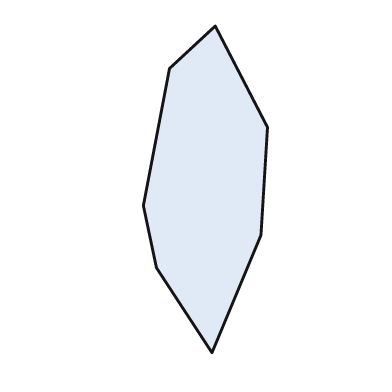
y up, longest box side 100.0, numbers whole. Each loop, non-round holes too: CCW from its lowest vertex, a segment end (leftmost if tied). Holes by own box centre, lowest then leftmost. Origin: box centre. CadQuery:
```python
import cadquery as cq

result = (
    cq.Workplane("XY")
    .moveTo(2.0, -50.0)
    .lineTo(17.0, -14.0)
    .lineTo(19.0, 19.0)
    .lineTo(3.0, 50.0)
    .lineTo(-11.0, 37.0)
    .lineTo(-19.0, -5.0)
    .lineTo(-15.0, -24.0)
    .close()
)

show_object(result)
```